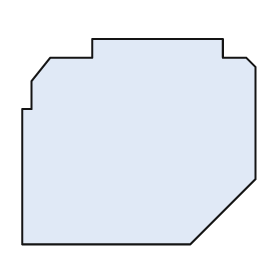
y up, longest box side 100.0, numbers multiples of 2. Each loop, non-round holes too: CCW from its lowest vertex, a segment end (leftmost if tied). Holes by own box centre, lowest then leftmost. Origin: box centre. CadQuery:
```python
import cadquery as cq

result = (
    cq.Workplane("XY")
    .moveTo(-50.0, -44.0)
    .lineTo(22.0, -44.0)
    .lineTo(50.0, -16.0)
    .lineTo(50.0, 32.0)
    .lineTo(46.0, 36.0)
    .lineTo(36.0, 36.0)
    .lineTo(36.0, 44.0)
    .lineTo(-20.0, 44.0)
    .lineTo(-20.0, 36.0)
    .lineTo(-38.0, 36.0)
    .lineTo(-46.0, 26.0)
    .lineTo(-46.0, 14.0)
    .lineTo(-50.0, 14.0)
    .close()
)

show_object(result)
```